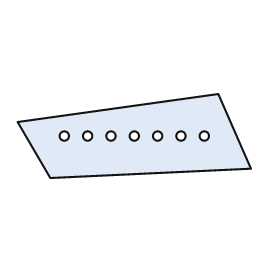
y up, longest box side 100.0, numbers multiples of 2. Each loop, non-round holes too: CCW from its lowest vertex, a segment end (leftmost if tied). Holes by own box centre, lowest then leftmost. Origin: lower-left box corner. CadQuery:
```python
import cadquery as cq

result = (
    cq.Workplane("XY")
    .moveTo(14.0, 0.0)
    .lineTo(100.0, 4.0)
    .lineTo(86.0, 36.0)
    .lineTo(0.0, 24.0)
    .close()
    .moveTo(20.0, 18.0)
    .circle(2.0)
    .moveTo(30.0, 18.0)
    .circle(2.0)
    .moveTo(40.0, 18.0)
    .circle(2.0)
    .moveTo(50.0, 18.0)
    .circle(2.0)
    .moveTo(60.0, 18.0)
    .circle(2.0)
    .moveTo(70.0, 18.0)
    .circle(2.0)
    .moveTo(80.0, 18.0)
    .circle(2.0)
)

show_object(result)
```